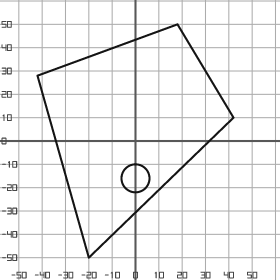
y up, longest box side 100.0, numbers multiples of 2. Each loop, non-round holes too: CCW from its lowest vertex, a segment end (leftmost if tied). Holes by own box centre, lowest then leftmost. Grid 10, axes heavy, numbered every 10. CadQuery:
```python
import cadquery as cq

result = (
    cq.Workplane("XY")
    .moveTo(-20.0, -50.0)
    .lineTo(42.0, 10.0)
    .lineTo(18.0, 50.0)
    .lineTo(-42.0, 28.0)
    .close()
    .moveTo(0.0, -16.0)
    .circle(6.0)
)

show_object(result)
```